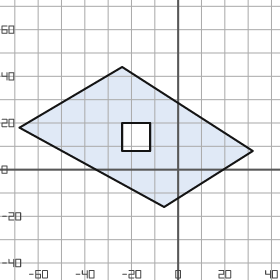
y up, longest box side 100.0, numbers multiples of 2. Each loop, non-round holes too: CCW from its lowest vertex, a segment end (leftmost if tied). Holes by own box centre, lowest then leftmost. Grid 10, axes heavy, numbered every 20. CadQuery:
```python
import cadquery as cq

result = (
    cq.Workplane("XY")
    .moveTo(-6.0, -16.0)
    .lineTo(32.0, 8.0)
    .lineTo(-24.0, 44.0)
    .lineTo(-68.0, 18.0)
    .close()
    .moveTo(-24.0, 8.0)
    .lineTo(-12.0, 8.0)
    .lineTo(-12.0, 20.0)
    .lineTo(-24.0, 20.0)
    .close()
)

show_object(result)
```